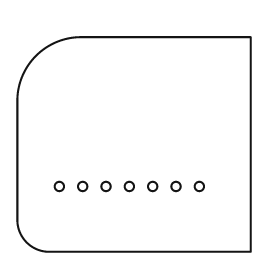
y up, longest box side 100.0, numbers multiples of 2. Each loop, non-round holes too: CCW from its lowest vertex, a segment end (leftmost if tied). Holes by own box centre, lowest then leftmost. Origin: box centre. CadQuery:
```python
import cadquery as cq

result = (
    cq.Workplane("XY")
    .moveTo(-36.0, -46.0)
    .lineTo(50.0, -46.0)
    .lineTo(50.0, 46.0)
    .lineTo(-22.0, 46.0)
    .threePointArc((-42.0, 38.0), (-50.0, 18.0))
    .lineTo(-50.0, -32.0)
    .threePointArc((-46.0, -42.0), (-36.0, -46.0))
    .close()
    .moveTo(-32.0, -18.0)
    .circle(2.0)
    .moveTo(-22.0, -18.0)
    .circle(2.0)
    .moveTo(-12.0, -18.0)
    .circle(2.0)
    .moveTo(-2.0, -18.0)
    .circle(2.0)
    .moveTo(8.0, -18.0)
    .circle(2.0)
    .moveTo(18.0, -18.0)
    .circle(2.0)
    .moveTo(28.0, -18.0)
    .circle(2.0)
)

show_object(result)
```